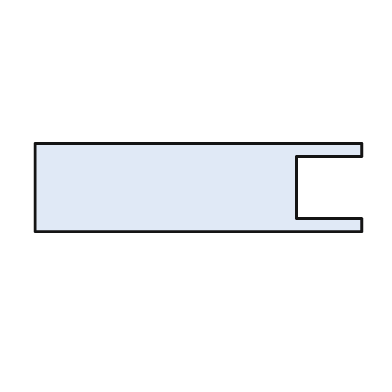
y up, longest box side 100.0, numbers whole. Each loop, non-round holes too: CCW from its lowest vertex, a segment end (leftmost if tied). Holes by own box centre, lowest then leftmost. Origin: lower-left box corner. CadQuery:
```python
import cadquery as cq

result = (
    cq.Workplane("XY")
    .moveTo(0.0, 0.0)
    .lineTo(100.0, 0.0)
    .lineTo(100.0, 4.0)
    .lineTo(80.0, 4.0)
    .lineTo(80.0, 23.0)
    .lineTo(100.0, 23.0)
    .lineTo(100.0, 27.0)
    .lineTo(0.0, 27.0)
    .close()
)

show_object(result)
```